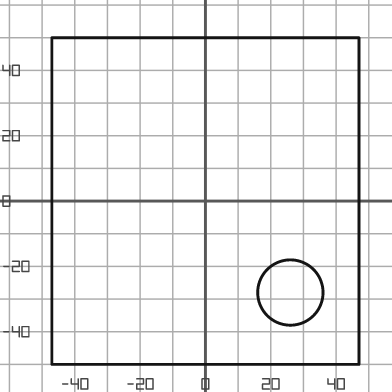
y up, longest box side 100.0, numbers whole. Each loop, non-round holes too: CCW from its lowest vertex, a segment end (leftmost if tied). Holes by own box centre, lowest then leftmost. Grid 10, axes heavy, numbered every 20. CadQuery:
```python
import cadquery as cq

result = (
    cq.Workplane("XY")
    .moveTo(-47.0, -50.0)
    .lineTo(47.0, -50.0)
    .lineTo(47.0, 50.0)
    .lineTo(-47.0, 50.0)
    .close()
    .moveTo(26.0, -28.0)
    .circle(10.0)
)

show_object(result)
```